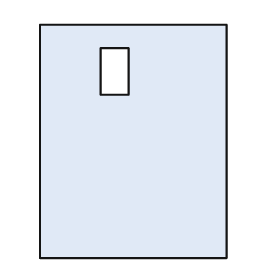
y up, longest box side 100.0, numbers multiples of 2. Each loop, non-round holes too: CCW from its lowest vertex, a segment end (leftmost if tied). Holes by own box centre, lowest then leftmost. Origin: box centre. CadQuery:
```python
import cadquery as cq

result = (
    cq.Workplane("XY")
    .moveTo(-40.0, -50.0)
    .lineTo(40.0, -50.0)
    .lineTo(40.0, 50.0)
    .lineTo(-40.0, 50.0)
    .close()
    .moveTo(-14.0, 20.0)
    .lineTo(-2.0, 20.0)
    .lineTo(-2.0, 40.0)
    .lineTo(-14.0, 40.0)
    .close()
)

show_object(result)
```